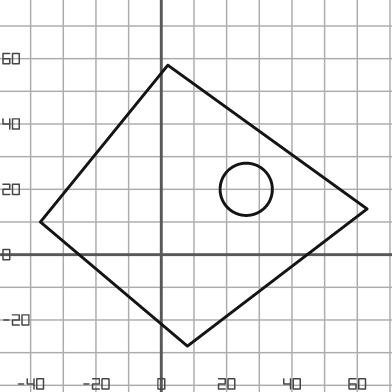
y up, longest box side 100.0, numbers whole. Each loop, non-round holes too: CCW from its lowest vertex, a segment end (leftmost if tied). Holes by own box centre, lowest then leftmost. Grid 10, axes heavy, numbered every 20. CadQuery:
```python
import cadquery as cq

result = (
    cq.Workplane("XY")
    .moveTo(8.0, -28.0)
    .lineTo(63.0, 14.0)
    .lineTo(2.0, 58.0)
    .lineTo(-37.0, 10.0)
    .close()
    .moveTo(26.0, 20.0)
    .circle(8.0)
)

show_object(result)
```